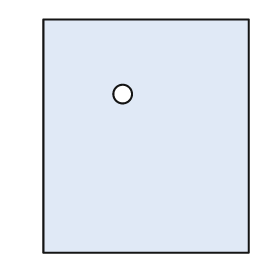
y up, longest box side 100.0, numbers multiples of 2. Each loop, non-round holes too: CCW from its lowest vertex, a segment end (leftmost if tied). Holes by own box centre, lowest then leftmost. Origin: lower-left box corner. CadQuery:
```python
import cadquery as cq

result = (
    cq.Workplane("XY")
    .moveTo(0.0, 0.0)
    .lineTo(88.0, 0.0)
    .lineTo(88.0, 100.0)
    .lineTo(0.0, 100.0)
    .close()
    .moveTo(34.0, 68.0)
    .circle(4.0)
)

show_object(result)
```